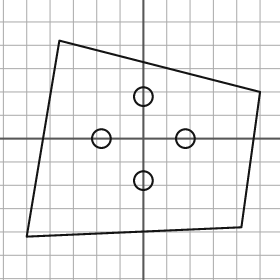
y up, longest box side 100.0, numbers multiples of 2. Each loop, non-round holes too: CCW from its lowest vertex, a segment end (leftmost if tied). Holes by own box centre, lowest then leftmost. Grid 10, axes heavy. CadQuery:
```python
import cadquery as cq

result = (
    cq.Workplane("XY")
    .moveTo(-50.0, -42.0)
    .lineTo(42.0, -38.0)
    .lineTo(50.0, 20.0)
    .lineTo(-36.0, 42.0)
    .close()
    .moveTo(0.0, -18.0)
    .circle(4.0)
    .moveTo(-18.0, 0.0)
    .circle(4.0)
    .moveTo(18.0, 0.0)
    .circle(4.0)
    .moveTo(0.0, 18.0)
    .circle(4.0)
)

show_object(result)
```